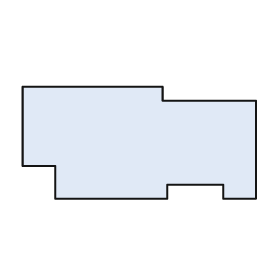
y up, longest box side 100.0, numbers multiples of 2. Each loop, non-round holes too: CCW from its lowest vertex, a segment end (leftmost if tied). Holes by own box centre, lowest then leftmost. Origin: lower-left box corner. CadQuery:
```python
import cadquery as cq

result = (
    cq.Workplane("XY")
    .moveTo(14.0, 0.0)
    .lineTo(62.0, 0.0)
    .lineTo(62.0, 6.0)
    .lineTo(86.0, 6.0)
    .lineTo(86.0, 0.0)
    .lineTo(100.0, 0.0)
    .lineTo(100.0, 42.0)
    .lineTo(60.0, 42.0)
    .lineTo(60.0, 48.0)
    .lineTo(0.0, 48.0)
    .lineTo(0.0, 14.0)
    .lineTo(14.0, 14.0)
    .close()
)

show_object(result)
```